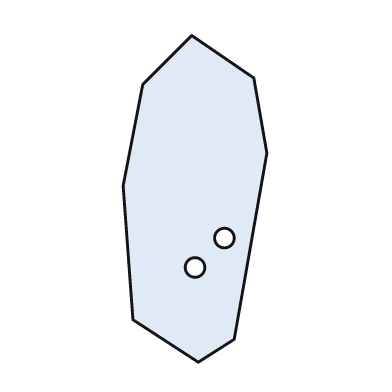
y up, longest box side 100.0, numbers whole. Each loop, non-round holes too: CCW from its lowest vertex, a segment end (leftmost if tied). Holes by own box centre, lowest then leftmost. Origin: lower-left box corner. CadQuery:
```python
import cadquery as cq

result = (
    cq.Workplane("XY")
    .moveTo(23.0, 0.0)
    .lineTo(34.0, 7.0)
    .lineTo(44.0, 64.0)
    .lineTo(40.0, 87.0)
    .lineTo(21.0, 100.0)
    .lineTo(6.0, 85.0)
    .lineTo(0.0, 54.0)
    .lineTo(3.0, 13.0)
    .close()
    .moveTo(22.0, 29.0)
    .circle(3.0)
    .moveTo(31.0, 38.0)
    .circle(3.0)
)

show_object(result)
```